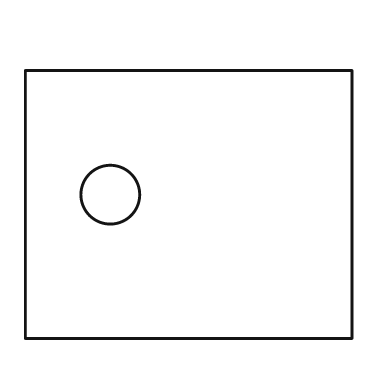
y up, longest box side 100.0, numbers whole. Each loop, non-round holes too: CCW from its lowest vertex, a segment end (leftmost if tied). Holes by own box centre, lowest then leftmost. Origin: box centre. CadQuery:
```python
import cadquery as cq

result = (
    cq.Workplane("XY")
    .moveTo(-50.0, -41.0)
    .lineTo(50.0, -41.0)
    .lineTo(50.0, 41.0)
    .lineTo(-50.0, 41.0)
    .close()
    .moveTo(-24.0, 3.0)
    .circle(9.0)
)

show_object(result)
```